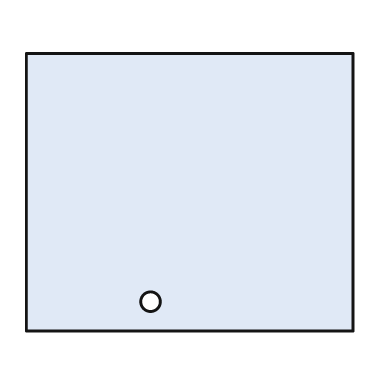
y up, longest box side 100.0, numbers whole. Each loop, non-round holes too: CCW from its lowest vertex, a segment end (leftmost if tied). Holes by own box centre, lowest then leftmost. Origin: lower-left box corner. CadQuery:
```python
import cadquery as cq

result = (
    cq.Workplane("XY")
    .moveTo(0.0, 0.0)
    .lineTo(100.0, 0.0)
    .lineTo(100.0, 85.0)
    .lineTo(0.0, 85.0)
    .close()
    .moveTo(38.0, 9.0)
    .circle(3.0)
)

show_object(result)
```